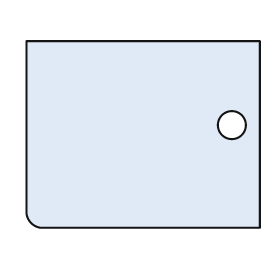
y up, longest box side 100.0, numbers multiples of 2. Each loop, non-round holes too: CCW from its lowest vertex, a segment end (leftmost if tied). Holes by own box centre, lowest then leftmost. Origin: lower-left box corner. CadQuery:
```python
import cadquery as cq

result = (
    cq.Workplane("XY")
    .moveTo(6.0, 0.0)
    .lineTo(100.0, 0.0)
    .lineTo(100.0, 80.0)
    .lineTo(0.0, 80.0)
    .lineTo(0.0, 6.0)
    .threePointArc((2.0, 2.0), (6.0, 0.0))
    .close()
    .moveTo(88.0, 44.0)
    .circle(6.0)
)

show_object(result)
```